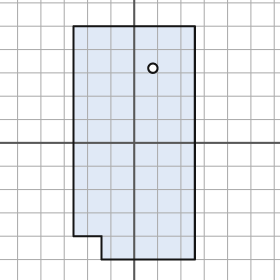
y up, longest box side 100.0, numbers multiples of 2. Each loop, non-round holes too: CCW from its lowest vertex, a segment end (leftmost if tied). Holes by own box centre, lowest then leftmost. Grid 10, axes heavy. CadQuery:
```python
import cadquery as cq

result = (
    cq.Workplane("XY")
    .moveTo(-14.0, -50.0)
    .lineTo(26.0, -50.0)
    .lineTo(26.0, 50.0)
    .lineTo(-26.0, 50.0)
    .lineTo(-26.0, -40.0)
    .lineTo(-14.0, -40.0)
    .close()
    .moveTo(8.0, 32.0)
    .circle(2.0)
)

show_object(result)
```